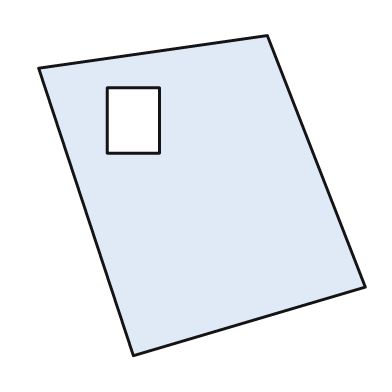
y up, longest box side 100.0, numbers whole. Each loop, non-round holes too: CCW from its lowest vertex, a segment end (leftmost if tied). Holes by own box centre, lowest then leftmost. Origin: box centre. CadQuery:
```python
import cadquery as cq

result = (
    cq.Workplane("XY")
    .moveTo(-21.0, -49.0)
    .lineTo(50.0, -28.0)
    .lineTo(20.0, 49.0)
    .lineTo(-50.0, 39.0)
    .close()
    .moveTo(-29.0, 13.0)
    .lineTo(-13.0, 13.0)
    .lineTo(-13.0, 33.0)
    .lineTo(-29.0, 33.0)
    .close()
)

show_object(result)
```